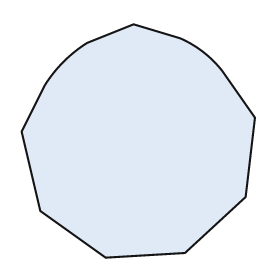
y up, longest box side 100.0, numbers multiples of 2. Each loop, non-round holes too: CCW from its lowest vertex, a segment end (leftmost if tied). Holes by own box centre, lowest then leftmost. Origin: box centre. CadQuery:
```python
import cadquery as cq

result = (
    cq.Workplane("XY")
    .moveTo(-14.0, -50.0)
    .lineTo(20.0, -48.0)
    .lineTo(46.0, -24.0)
    .lineTo(50.0, 10.0)
    .lineTo(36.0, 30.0)
    .threePointArc((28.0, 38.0), (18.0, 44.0))
    .lineTo(-2.0, 50.0)
    .lineTo(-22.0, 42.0)
    .threePointArc((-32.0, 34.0), (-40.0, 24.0))
    .lineTo(-50.0, 4.0)
    .lineTo(-42.0, -30.0)
    .close()
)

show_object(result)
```